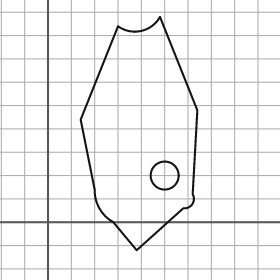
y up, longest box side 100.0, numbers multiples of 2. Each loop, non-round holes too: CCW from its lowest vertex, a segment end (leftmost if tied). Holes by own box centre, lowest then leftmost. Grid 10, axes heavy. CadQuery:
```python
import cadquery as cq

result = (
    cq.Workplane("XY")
    .moveTo(38.0, -12.0)
    .lineTo(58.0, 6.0)
    .threePointArc((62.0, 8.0), (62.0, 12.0))
    .lineTo(64.0, 48.0)
    .lineTo(48.0, 88.0)
    .threePointArc((40.0, 82.0), (30.0, 84.0))
    .lineTo(14.0, 44.0)
    .lineTo(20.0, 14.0)
    .threePointArc((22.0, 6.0), (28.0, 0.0))
    .close()
    .moveTo(50.0, 20.0)
    .circle(6.0)
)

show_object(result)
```